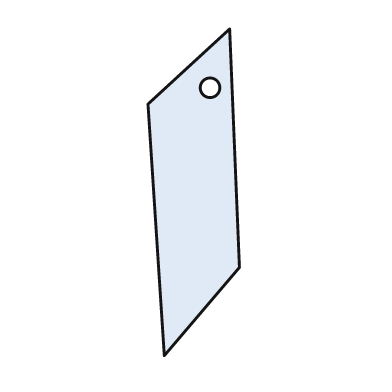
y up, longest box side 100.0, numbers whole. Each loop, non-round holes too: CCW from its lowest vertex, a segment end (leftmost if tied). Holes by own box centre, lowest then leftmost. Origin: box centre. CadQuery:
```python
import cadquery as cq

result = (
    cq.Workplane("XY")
    .moveTo(-9.0, -50.0)
    .lineTo(14.0, -23.0)
    .lineTo(11.0, 50.0)
    .lineTo(-14.0, 27.0)
    .close()
    .moveTo(5.0, 32.0)
    .circle(3.0)
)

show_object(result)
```